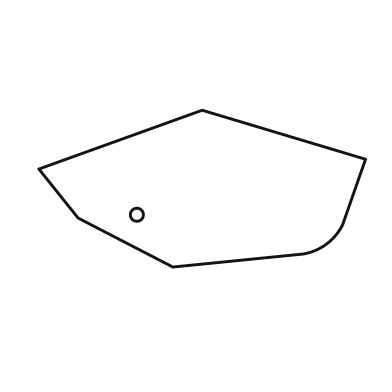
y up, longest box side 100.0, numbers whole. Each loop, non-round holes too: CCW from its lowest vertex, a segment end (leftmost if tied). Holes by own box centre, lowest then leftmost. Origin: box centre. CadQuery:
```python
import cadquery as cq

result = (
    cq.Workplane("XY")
    .moveTo(-9.0, -24.0)
    .lineTo(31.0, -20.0)
    .threePointArc((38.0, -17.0), (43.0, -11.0))
    .lineTo(50.0, 9.0)
    .lineTo(0.0, 24.0)
    .lineTo(-50.0, 6.0)
    .lineTo(-38.0, -9.0)
    .close()
    .moveTo(-20.0, -8.0)
    .circle(2.0)
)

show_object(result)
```